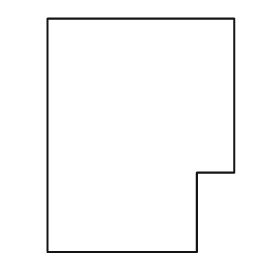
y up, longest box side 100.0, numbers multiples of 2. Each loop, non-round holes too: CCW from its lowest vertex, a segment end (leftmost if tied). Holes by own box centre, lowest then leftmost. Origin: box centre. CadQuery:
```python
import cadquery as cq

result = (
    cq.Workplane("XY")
    .moveTo(-40.0, -50.0)
    .lineTo(24.0, -50.0)
    .lineTo(24.0, -16.0)
    .lineTo(40.0, -16.0)
    .lineTo(40.0, 50.0)
    .lineTo(-40.0, 50.0)
    .close()
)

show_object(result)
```